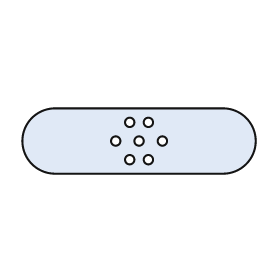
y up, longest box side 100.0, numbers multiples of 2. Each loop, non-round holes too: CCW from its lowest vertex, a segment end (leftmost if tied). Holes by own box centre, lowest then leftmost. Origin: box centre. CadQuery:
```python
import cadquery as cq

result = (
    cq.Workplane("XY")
    .moveTo(-36.0, -14.0)
    .lineTo(36.0, -14.0)
    .threePointArc((50.0, 0.0), (36.0, 14.0))
    .lineTo(-36.0, 14.0)
    .threePointArc((-50.0, 0.0), (-36.0, -14.0))
    .close()
    .moveTo(-4.0, -8.0)
    .circle(2.0)
    .moveTo(4.0, -8.0)
    .circle(2.0)
    .moveTo(-10.0, 0.0)
    .circle(2.0)
    .moveTo(0.0, 0.0)
    .circle(2.0)
    .moveTo(10.0, 0.0)
    .circle(2.0)
    .moveTo(-4.0, 8.0)
    .circle(2.0)
    .moveTo(4.0, 8.0)
    .circle(2.0)
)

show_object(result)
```